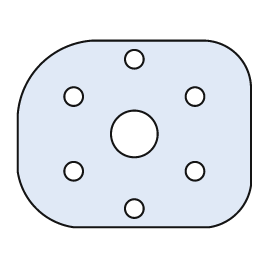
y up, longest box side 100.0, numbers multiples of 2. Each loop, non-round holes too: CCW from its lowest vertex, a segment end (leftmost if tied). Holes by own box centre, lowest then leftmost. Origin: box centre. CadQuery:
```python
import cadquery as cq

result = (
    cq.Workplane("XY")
    .moveTo(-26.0, -40.0)
    .lineTo(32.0, -40.0)
    .threePointArc((44.0, -34.0), (50.0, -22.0))
    .lineTo(50.0, 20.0)
    .threePointArc((44.0, 34.0), (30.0, 40.0))
    .lineTo(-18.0, 40.0)
    .threePointArc((-40.0, 30.0), (-50.0, 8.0))
    .lineTo(-50.0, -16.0)
    .threePointArc((-42.0, -32.0), (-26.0, -40.0))
    .close()
    .moveTo(0.0, -32.0)
    .circle(4.0)
    .moveTo(-26.0, -16.0)
    .circle(4.0)
    .moveTo(26.0, -16.0)
    .circle(4.0)
    .moveTo(0.0, 0.0)
    .circle(10.0)
    .moveTo(-26.0, 16.0)
    .circle(4.0)
    .moveTo(26.0, 16.0)
    .circle(4.0)
    .moveTo(0.0, 32.0)
    .circle(4.0)
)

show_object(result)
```